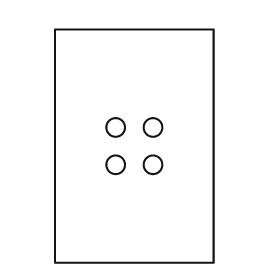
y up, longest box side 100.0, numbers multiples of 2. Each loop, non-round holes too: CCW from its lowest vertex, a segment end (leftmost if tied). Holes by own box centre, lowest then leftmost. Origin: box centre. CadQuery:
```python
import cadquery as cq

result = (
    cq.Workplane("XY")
    .moveTo(-34.0, -50.0)
    .lineTo(34.0, -50.0)
    .lineTo(34.0, 50.0)
    .lineTo(-34.0, 50.0)
    .close()
    .moveTo(-8.0, -8.0)
    .circle(4.0)
    .moveTo(8.0, -8.0)
    .circle(4.0)
    .moveTo(-8.0, 8.0)
    .circle(4.0)
    .moveTo(8.0, 8.0)
    .circle(4.0)
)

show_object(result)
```